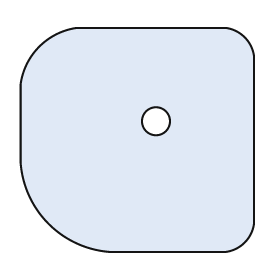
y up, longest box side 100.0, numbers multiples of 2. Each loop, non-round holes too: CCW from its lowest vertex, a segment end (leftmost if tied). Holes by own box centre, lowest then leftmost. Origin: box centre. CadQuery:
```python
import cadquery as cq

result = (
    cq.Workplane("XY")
    .moveTo(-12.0, -48.0)
    .lineTo(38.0, -48.0)
    .threePointArc((46.0, -44.0), (50.0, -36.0))
    .lineTo(50.0, 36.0)
    .threePointArc((46.0, 44.0), (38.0, 48.0))
    .lineTo(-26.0, 48.0)
    .threePointArc((-42.0, 40.0), (-50.0, 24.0))
    .lineTo(-50.0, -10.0)
    .threePointArc((-38.0, -36.0), (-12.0, -48.0))
    .close()
    .moveTo(8.0, 8.0)
    .circle(6.0)
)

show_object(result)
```